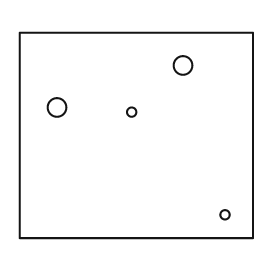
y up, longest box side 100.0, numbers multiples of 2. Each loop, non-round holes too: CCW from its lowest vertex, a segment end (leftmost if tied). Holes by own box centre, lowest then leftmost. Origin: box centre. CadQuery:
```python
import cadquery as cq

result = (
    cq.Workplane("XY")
    .moveTo(-50.0, -44.0)
    .lineTo(50.0, -44.0)
    .lineTo(50.0, 44.0)
    .lineTo(-50.0, 44.0)
    .close()
    .moveTo(38.0, -34.0)
    .circle(2.0)
    .moveTo(-2.0, 10.0)
    .circle(2.0)
    .moveTo(-34.0, 12.0)
    .circle(4.0)
    .moveTo(20.0, 30.0)
    .circle(4.0)
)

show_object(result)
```